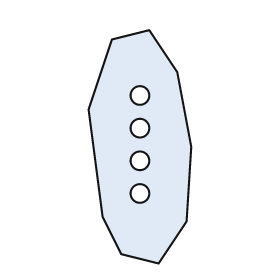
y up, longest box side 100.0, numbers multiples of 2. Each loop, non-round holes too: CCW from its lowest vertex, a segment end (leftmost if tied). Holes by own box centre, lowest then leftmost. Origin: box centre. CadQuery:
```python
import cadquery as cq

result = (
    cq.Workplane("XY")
    .moveTo(8.0, -50.0)
    .lineTo(20.0, -32.0)
    .lineTo(22.0, 0.0)
    .lineTo(16.0, 32.0)
    .lineTo(4.0, 50.0)
    .lineTo(-12.0, 46.0)
    .lineTo(-22.0, 16.0)
    .lineTo(-16.0, -30.0)
    .lineTo(-8.0, -46.0)
    .close()
    .moveTo(0.0, -20.0)
    .circle(4.0)
    .moveTo(0.0, -6.0)
    .circle(4.0)
    .moveTo(0.0, 8.0)
    .circle(4.0)
    .moveTo(0.0, 22.0)
    .circle(4.0)
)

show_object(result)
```